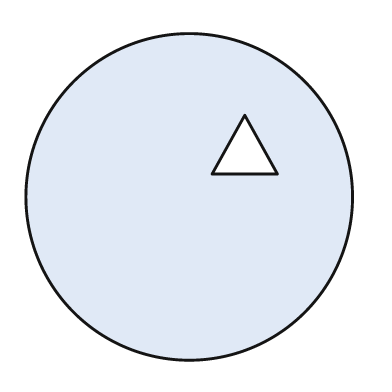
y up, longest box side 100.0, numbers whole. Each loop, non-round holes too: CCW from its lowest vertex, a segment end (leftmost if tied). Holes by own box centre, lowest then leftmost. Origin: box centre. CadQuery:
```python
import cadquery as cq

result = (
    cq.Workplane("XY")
    .moveTo(0.0, 0.0)
    .circle(50.0)
    .moveTo(7.0, 7.0)
    .lineTo(27.0, 7.0)
    .lineTo(17.0, 25.0)
    .close()
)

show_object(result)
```